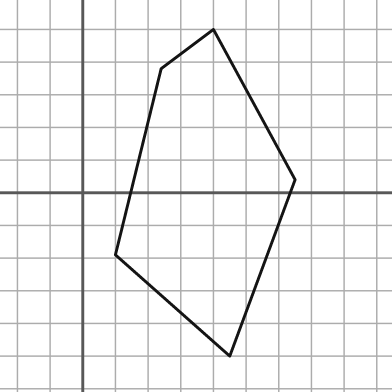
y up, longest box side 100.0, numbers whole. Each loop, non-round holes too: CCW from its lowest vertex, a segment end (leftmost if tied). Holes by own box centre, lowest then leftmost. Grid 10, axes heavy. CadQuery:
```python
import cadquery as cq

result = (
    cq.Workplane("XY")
    .moveTo(45.0, -50.0)
    .lineTo(65.0, 4.0)
    .lineTo(40.0, 50.0)
    .lineTo(24.0, 38.0)
    .lineTo(10.0, -19.0)
    .close()
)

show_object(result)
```